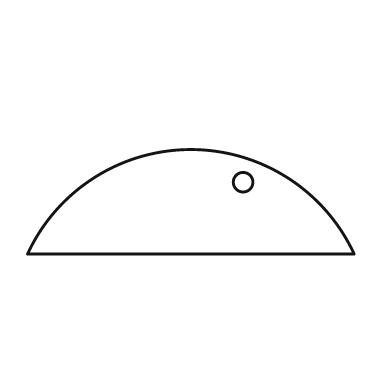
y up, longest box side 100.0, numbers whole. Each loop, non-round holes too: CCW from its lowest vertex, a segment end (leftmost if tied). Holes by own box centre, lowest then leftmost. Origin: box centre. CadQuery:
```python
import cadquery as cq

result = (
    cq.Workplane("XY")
    .moveTo(-50.0, -16.0)
    .lineTo(50.0, -16.0)
    .threePointArc((0.0, 16.0), (-50.0, -16.0))
    .close()
    .moveTo(16.0, 6.0)
    .circle(3.0)
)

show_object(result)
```